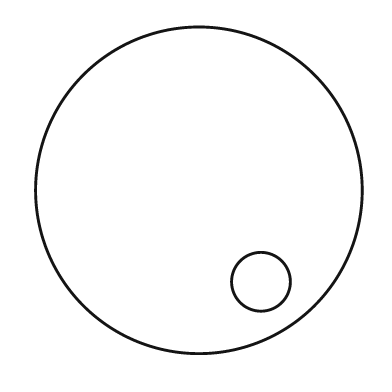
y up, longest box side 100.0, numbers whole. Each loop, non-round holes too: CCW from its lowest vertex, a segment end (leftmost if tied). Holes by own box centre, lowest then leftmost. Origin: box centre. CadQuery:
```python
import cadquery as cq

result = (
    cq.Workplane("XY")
    .moveTo(0.0, 0.0)
    .circle(50.0)
    .moveTo(19.0, -28.0)
    .circle(9.0)
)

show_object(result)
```